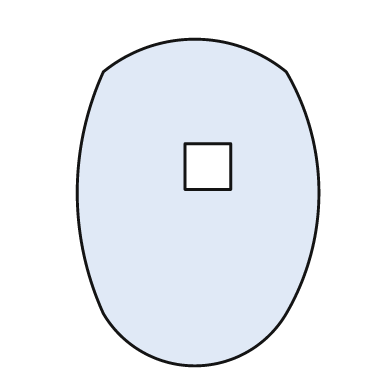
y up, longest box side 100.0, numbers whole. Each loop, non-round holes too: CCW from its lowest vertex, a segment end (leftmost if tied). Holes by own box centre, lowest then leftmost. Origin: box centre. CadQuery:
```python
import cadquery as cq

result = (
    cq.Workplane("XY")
    .moveTo(-29.0, -34.0)
    .threePointArc((-1.0, -50.0), (27.0, -34.0))
    .threePointArc((37.0, 3.0), (27.0, 40.0))
    .threePointArc((-1.0, 50.0), (-29.0, 40.0))
    .threePointArc((-37.0, 3.0), (-29.0, -34.0))
    .close()
    .moveTo(-4.0, 4.0)
    .lineTo(10.0, 4.0)
    .lineTo(10.0, 18.0)
    .lineTo(-4.0, 18.0)
    .close()
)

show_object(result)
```